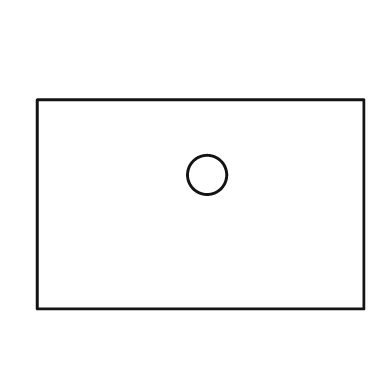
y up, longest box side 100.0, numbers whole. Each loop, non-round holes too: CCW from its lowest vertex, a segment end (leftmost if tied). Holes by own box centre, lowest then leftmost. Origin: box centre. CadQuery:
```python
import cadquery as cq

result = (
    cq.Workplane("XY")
    .moveTo(-50.0, -32.0)
    .lineTo(50.0, -32.0)
    .lineTo(50.0, 32.0)
    .lineTo(-50.0, 32.0)
    .close()
    .moveTo(2.0, 9.0)
    .circle(6.0)
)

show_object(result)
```